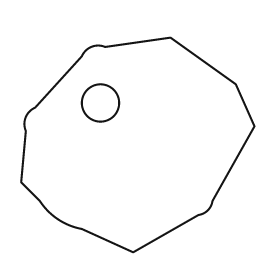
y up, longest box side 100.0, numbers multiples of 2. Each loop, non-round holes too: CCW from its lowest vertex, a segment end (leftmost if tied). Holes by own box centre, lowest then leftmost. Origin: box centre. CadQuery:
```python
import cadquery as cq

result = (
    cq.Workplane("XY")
    .moveTo(-2.0, -46.0)
    .lineTo(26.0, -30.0)
    .threePointArc((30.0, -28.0), (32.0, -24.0))
    .lineTo(50.0, 8.0)
    .lineTo(42.0, 26.0)
    .lineTo(14.0, 46.0)
    .lineTo(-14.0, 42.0)
    .threePointArc((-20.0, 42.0), (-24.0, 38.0))
    .lineTo(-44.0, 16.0)
    .threePointArc((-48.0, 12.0), (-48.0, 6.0))
    .lineTo(-50.0, -16.0)
    .lineTo(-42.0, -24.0)
    .threePointArc((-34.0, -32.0), (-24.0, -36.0))
    .close()
    .moveTo(-16.0, 18.0)
    .circle(8.0)
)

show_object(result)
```